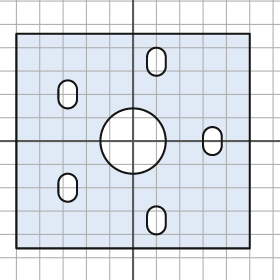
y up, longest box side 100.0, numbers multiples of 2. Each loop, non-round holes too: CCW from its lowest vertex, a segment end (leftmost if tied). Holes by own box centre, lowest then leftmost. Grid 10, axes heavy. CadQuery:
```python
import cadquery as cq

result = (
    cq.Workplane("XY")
    .moveTo(-50.0, -46.0)
    .lineTo(50.0, -46.0)
    .lineTo(50.0, 46.0)
    .lineTo(-50.0, 46.0)
    .close()
    .moveTo(6.0, -36.0)
    .threePointArc((10.0, -40.0), (14.0, -36.0))
    .lineTo(14.0, -32.0)
    .threePointArc((10.0, -28.0), (6.0, -32.0))
    .close()
    .moveTo(-32.0, -22.0)
    .threePointArc((-28.0, -26.0), (-24.0, -22.0))
    .lineTo(-24.0, -18.0)
    .threePointArc((-28.0, -14.0), (-32.0, -18.0))
    .close()
    .moveTo(0.0, 0.0)
    .circle(14.0)
    .moveTo(30.0, -2.0)
    .threePointArc((34.0, -6.0), (38.0, -2.0))
    .lineTo(38.0, 2.0)
    .threePointArc((34.0, 6.0), (30.0, 2.0))
    .close()
    .moveTo(-32.0, 18.0)
    .threePointArc((-28.0, 14.0), (-24.0, 18.0))
    .lineTo(-24.0, 22.0)
    .threePointArc((-28.0, 26.0), (-32.0, 22.0))
    .close()
    .moveTo(6.0, 32.0)
    .threePointArc((10.0, 28.0), (14.0, 32.0))
    .lineTo(14.0, 36.0)
    .threePointArc((10.0, 40.0), (6.0, 36.0))
    .close()
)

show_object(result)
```